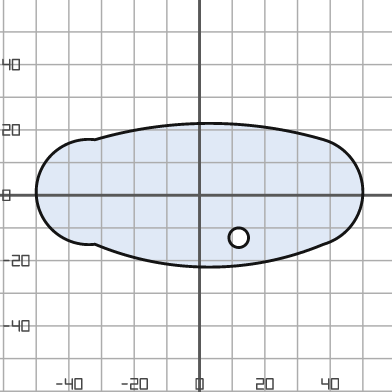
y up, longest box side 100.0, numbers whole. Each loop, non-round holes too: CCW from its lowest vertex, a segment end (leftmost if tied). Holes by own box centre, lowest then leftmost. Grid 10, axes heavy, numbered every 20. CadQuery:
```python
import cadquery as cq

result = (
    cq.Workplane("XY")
    .moveTo(-32.0, -15.0)
    .threePointArc((3.0, -22.0), (38.0, -15.0))
    .threePointArc((50.0, 1.0), (38.0, 17.0))
    .threePointArc((3.0, 22.0), (-32.0, 17.0))
    .threePointArc((-50.0, 1.0), (-32.0, -15.0))
    .close()
    .moveTo(12.0, -13.0)
    .circle(3.0)
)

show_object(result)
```